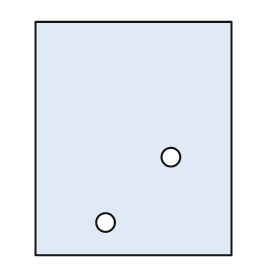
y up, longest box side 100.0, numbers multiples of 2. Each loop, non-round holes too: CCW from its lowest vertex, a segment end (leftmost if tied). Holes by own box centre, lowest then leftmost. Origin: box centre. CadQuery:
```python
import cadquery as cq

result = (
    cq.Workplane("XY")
    .moveTo(-42.0, -50.0)
    .lineTo(42.0, -50.0)
    .lineTo(42.0, 50.0)
    .lineTo(-42.0, 50.0)
    .close()
    .moveTo(-12.0, -36.0)
    .circle(4.0)
    .moveTo(16.0, -8.0)
    .circle(4.0)
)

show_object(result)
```